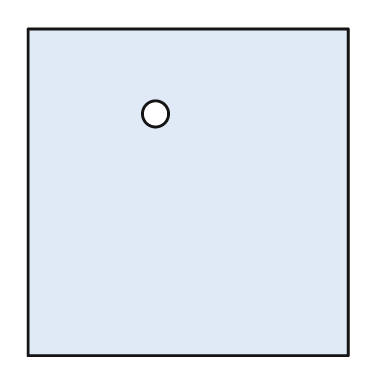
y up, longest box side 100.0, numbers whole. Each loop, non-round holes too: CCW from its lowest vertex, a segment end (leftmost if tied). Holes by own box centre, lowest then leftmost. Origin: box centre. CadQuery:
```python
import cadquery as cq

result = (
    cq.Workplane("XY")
    .moveTo(-49.0, -50.0)
    .lineTo(49.0, -50.0)
    .lineTo(49.0, 50.0)
    .lineTo(-49.0, 50.0)
    .close()
    .moveTo(-10.0, 24.0)
    .circle(4.0)
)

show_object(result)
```